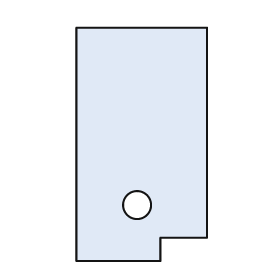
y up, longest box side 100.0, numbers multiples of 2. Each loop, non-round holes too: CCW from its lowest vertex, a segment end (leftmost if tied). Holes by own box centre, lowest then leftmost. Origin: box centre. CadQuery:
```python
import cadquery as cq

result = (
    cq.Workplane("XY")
    .moveTo(-28.0, -50.0)
    .lineTo(8.0, -50.0)
    .lineTo(8.0, -40.0)
    .lineTo(28.0, -40.0)
    .lineTo(28.0, 50.0)
    .lineTo(-28.0, 50.0)
    .close()
    .moveTo(-2.0, -26.0)
    .circle(6.0)
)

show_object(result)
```